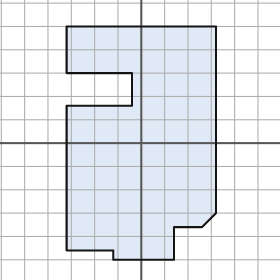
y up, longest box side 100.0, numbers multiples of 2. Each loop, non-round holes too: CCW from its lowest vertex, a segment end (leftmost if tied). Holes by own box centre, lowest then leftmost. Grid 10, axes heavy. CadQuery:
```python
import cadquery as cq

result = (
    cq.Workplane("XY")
    .moveTo(-12.0, -50.0)
    .lineTo(14.0, -50.0)
    .lineTo(14.0, -36.0)
    .lineTo(26.0, -36.0)
    .lineTo(32.0, -30.0)
    .lineTo(32.0, 50.0)
    .lineTo(-32.0, 50.0)
    .lineTo(-32.0, 30.0)
    .lineTo(-4.0, 30.0)
    .lineTo(-4.0, 16.0)
    .lineTo(-32.0, 16.0)
    .lineTo(-32.0, -46.0)
    .lineTo(-12.0, -46.0)
    .close()
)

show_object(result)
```